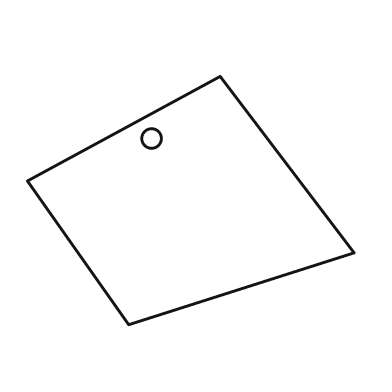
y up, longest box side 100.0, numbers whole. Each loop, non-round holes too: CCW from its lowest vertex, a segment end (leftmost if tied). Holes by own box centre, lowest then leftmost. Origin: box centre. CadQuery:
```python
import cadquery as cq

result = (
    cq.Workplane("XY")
    .moveTo(-19.0, -38.0)
    .lineTo(50.0, -16.0)
    .lineTo(9.0, 38.0)
    .lineTo(-50.0, 6.0)
    .close()
    .moveTo(-12.0, 19.0)
    .circle(3.0)
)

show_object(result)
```